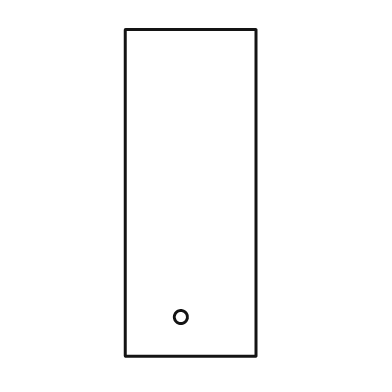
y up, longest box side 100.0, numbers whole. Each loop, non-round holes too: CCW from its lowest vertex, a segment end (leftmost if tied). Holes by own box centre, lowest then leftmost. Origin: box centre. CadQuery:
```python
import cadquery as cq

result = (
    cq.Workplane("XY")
    .moveTo(-20.0, -50.0)
    .lineTo(20.0, -50.0)
    .lineTo(20.0, 50.0)
    .lineTo(-20.0, 50.0)
    .close()
    .moveTo(-3.0, -38.0)
    .circle(2.0)
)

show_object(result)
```